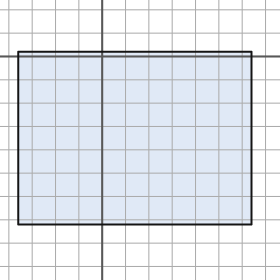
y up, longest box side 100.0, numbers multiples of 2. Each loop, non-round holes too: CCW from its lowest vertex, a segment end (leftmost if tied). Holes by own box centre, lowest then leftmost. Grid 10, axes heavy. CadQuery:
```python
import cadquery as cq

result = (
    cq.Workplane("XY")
    .moveTo(-36.0, -72.0)
    .lineTo(64.0, -72.0)
    .lineTo(64.0, 2.0)
    .lineTo(-36.0, 2.0)
    .close()
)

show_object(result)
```